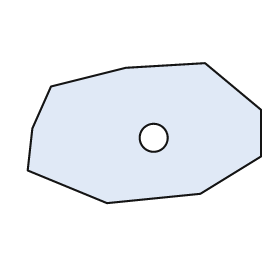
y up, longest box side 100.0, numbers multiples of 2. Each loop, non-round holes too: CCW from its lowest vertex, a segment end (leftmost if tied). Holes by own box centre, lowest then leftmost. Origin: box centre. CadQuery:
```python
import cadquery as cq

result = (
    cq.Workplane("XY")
    .moveTo(-16.0, -30.0)
    .lineTo(24.0, -26.0)
    .lineTo(50.0, -10.0)
    .lineTo(50.0, 10.0)
    .lineTo(26.0, 30.0)
    .lineTo(-8.0, 28.0)
    .lineTo(-40.0, 20.0)
    .lineTo(-48.0, 2.0)
    .lineTo(-50.0, -16.0)
    .close()
    .moveTo(4.0, -2.0)
    .circle(6.0)
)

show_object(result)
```